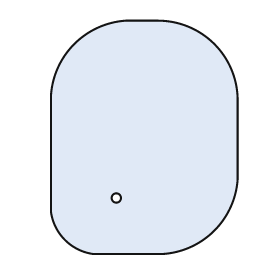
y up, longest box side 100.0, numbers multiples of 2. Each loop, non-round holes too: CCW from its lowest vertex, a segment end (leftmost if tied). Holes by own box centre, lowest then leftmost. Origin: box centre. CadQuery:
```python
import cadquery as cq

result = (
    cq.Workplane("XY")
    .moveTo(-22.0, -50.0)
    .lineTo(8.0, -50.0)
    .threePointArc((30.0, -40.0), (40.0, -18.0))
    .lineTo(40.0, 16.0)
    .threePointArc((30.0, 40.0), (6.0, 50.0))
    .lineTo(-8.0, 50.0)
    .threePointArc((-30.0, 40.0), (-40.0, 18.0))
    .lineTo(-40.0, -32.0)
    .threePointArc((-34.0, -44.0), (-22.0, -50.0))
    .close()
    .moveTo(-12.0, -26.0)
    .circle(2.0)
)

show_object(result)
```